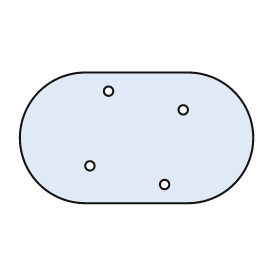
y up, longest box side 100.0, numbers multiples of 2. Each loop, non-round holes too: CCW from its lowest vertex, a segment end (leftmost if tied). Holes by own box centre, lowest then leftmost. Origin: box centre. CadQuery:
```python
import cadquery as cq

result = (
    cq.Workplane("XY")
    .moveTo(-22.0, -28.0)
    .lineTo(22.0, -28.0)
    .threePointArc((50.0, 0.0), (22.0, 28.0))
    .lineTo(-22.0, 28.0)
    .threePointArc((-50.0, 0.0), (-22.0, -28.0))
    .close()
    .moveTo(12.0, -20.0)
    .circle(2.0)
    .moveTo(-20.0, -12.0)
    .circle(2.0)
    .moveTo(20.0, 12.0)
    .circle(2.0)
    .moveTo(-12.0, 20.0)
    .circle(2.0)
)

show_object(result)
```